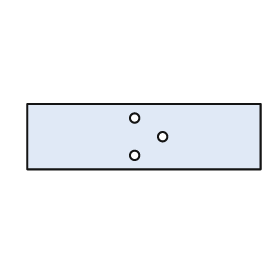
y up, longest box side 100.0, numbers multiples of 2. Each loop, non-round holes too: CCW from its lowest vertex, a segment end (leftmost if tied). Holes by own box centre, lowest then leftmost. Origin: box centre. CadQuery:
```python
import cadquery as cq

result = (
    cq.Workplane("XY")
    .moveTo(-50.0, -14.0)
    .lineTo(50.0, -14.0)
    .lineTo(50.0, 14.0)
    .lineTo(-50.0, 14.0)
    .close()
    .moveTo(-4.0, -8.0)
    .circle(2.0)
    .moveTo(8.0, 0.0)
    .circle(2.0)
    .moveTo(-4.0, 8.0)
    .circle(2.0)
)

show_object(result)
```